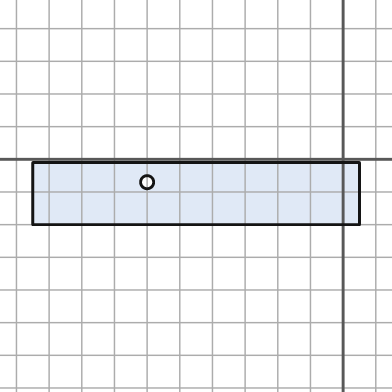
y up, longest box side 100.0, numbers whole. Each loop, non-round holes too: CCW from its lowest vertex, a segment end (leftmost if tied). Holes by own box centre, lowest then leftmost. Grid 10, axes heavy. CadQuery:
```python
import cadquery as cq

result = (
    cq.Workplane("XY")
    .moveTo(-95.0, -20.0)
    .lineTo(5.0, -20.0)
    .lineTo(5.0, -1.0)
    .lineTo(-95.0, -1.0)
    .close()
    .moveTo(-60.0, -7.0)
    .circle(2.0)
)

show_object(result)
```